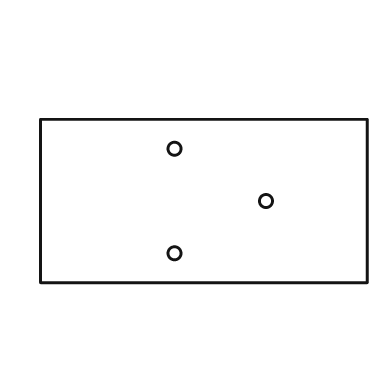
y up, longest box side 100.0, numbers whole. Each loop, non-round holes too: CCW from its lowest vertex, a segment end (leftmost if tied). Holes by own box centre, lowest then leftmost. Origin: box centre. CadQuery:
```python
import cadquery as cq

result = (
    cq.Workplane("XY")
    .moveTo(-50.0, -25.0)
    .lineTo(50.0, -25.0)
    .lineTo(50.0, 25.0)
    .lineTo(-50.0, 25.0)
    .close()
    .moveTo(-9.0, -16.0)
    .circle(2.0)
    .moveTo(19.0, 0.0)
    .circle(2.0)
    .moveTo(-9.0, 16.0)
    .circle(2.0)
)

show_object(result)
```